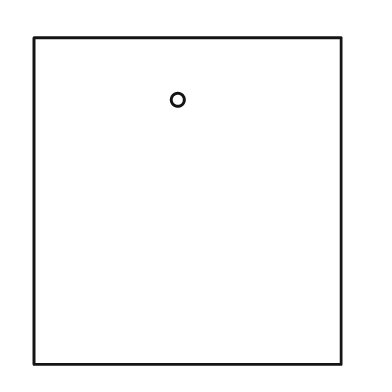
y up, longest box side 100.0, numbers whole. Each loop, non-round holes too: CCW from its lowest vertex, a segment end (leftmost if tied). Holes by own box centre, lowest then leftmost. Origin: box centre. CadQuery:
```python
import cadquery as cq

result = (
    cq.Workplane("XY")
    .moveTo(-47.0, -50.0)
    .lineTo(47.0, -50.0)
    .lineTo(47.0, 50.0)
    .lineTo(-47.0, 50.0)
    .close()
    .moveTo(-3.0, 31.0)
    .circle(2.0)
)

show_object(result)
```